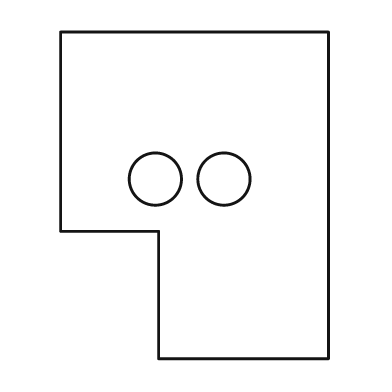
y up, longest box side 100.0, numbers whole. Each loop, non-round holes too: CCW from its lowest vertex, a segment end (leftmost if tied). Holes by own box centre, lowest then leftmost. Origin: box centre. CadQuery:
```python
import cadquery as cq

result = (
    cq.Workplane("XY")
    .moveTo(-11.0, -50.0)
    .lineTo(41.0, -50.0)
    .lineTo(41.0, 50.0)
    .lineTo(-41.0, 50.0)
    .lineTo(-41.0, -11.0)
    .lineTo(-11.0, -11.0)
    .close()
    .moveTo(-12.0, 5.0)
    .circle(8.0)
    .moveTo(9.0, 5.0)
    .circle(8.0)
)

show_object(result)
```